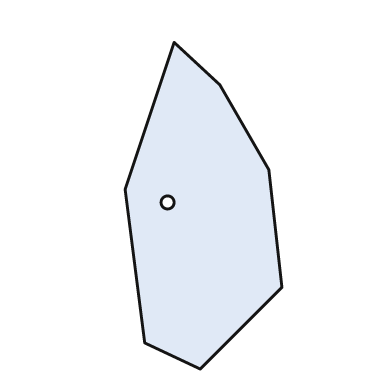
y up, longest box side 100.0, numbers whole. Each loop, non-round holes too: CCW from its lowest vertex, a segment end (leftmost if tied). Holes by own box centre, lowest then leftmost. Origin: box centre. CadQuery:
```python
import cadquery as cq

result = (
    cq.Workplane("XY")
    .moveTo(-1.0, -50.0)
    .lineTo(24.0, -25.0)
    .lineTo(20.0, 11.0)
    .lineTo(5.0, 37.0)
    .lineTo(-9.0, 50.0)
    .lineTo(-24.0, 5.0)
    .lineTo(-18.0, -42.0)
    .close()
    .moveTo(-11.0, 1.0)
    .circle(2.0)
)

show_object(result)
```